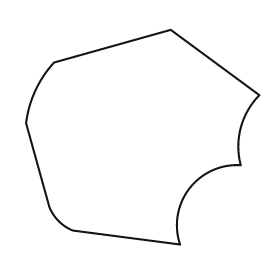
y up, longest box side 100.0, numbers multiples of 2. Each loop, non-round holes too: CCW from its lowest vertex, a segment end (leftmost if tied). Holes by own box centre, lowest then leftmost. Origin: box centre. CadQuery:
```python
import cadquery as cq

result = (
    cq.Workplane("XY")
    .moveTo(16.0, -46.0)
    .threePointArc((20.0, -22.0), (42.0, -12.0))
    .threePointArc((42.0, 4.0), (50.0, 18.0))
    .lineTo(12.0, 46.0)
    .lineTo(-38.0, 32.0)
    .threePointArc((-46.0, 20.0), (-50.0, 6.0))
    .lineTo(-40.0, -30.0)
    .threePointArc((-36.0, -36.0), (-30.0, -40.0))
    .close()
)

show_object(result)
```